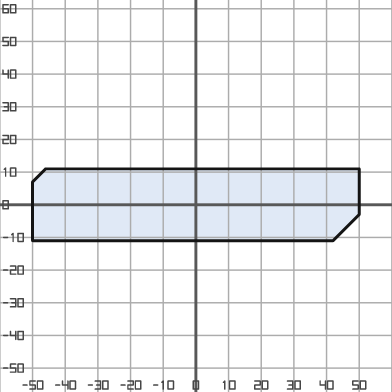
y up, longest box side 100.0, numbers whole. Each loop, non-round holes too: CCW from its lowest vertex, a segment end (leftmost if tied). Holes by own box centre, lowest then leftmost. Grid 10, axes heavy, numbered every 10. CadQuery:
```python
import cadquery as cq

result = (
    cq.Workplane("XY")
    .moveTo(-50.0, -11.0)
    .lineTo(42.0, -11.0)
    .lineTo(50.0, -3.0)
    .lineTo(50.0, 11.0)
    .lineTo(-46.0, 11.0)
    .lineTo(-50.0, 7.0)
    .close()
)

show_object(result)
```